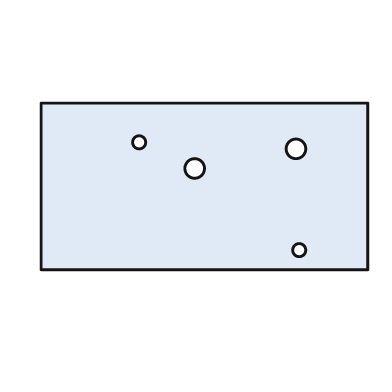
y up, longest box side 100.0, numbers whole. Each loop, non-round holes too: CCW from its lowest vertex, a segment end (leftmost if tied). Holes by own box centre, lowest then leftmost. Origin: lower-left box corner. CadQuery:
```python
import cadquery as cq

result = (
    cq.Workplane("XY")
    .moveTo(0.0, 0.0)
    .lineTo(100.0, 0.0)
    .lineTo(100.0, 51.0)
    .lineTo(0.0, 51.0)
    .close()
    .moveTo(79.0, 6.0)
    .circle(2.0)
    .moveTo(47.0, 31.0)
    .circle(3.0)
    .moveTo(78.0, 37.0)
    .circle(3.0)
    .moveTo(30.0, 39.0)
    .circle(2.0)
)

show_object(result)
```